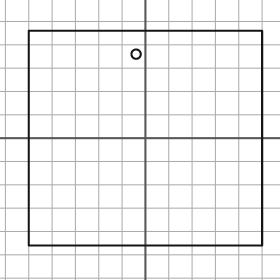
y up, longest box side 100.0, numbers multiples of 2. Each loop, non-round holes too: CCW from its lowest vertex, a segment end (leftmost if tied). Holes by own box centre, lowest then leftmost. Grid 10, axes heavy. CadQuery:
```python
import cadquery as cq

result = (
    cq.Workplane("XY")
    .moveTo(-50.0, -46.0)
    .lineTo(50.0, -46.0)
    .lineTo(50.0, 46.0)
    .lineTo(-50.0, 46.0)
    .close()
    .moveTo(-4.0, 36.0)
    .circle(2.0)
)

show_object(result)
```